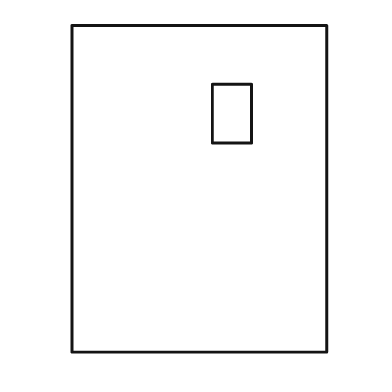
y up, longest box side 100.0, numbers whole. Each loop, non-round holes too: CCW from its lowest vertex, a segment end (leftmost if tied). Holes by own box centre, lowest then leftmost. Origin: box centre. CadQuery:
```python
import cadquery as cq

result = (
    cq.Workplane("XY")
    .moveTo(-39.0, -50.0)
    .lineTo(39.0, -50.0)
    .lineTo(39.0, 50.0)
    .lineTo(-39.0, 50.0)
    .close()
    .moveTo(4.0, 14.0)
    .lineTo(16.0, 14.0)
    .lineTo(16.0, 32.0)
    .lineTo(4.0, 32.0)
    .close()
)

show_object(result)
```